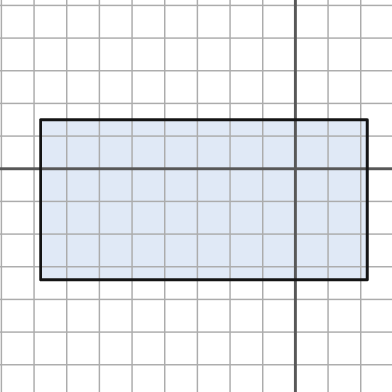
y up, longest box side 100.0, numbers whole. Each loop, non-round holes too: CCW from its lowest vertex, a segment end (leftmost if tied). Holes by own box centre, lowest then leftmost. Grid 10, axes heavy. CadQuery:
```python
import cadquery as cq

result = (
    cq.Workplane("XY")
    .moveTo(-78.0, -34.0)
    .lineTo(22.0, -34.0)
    .lineTo(22.0, 15.0)
    .lineTo(-78.0, 15.0)
    .close()
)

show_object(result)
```